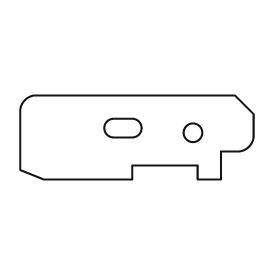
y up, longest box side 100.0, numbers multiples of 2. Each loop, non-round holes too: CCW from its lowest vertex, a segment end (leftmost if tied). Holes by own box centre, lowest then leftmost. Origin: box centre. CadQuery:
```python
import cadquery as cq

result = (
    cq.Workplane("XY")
    .moveTo(-40.0, -18.0)
    .lineTo(-2.0, -18.0)
    .lineTo(-2.0, -12.0)
    .lineTo(26.0, -12.0)
    .lineTo(26.0, -18.0)
    .lineTo(36.0, -18.0)
    .lineTo(36.0, -6.0)
    .lineTo(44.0, -6.0)
    .threePointArc((48.0, -4.0), (50.0, 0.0))
    .lineTo(50.0, 10.0)
    .lineTo(42.0, 18.0)
    .lineTo(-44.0, 18.0)
    .threePointArc((-48.0, 16.0), (-50.0, 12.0))
    .lineTo(-50.0, -14.0)
    .close()
    .moveTo(24.0, 2.0)
    .circle(4.0)
    .moveTo(-10.0, 0.0)
    .lineTo(-2.0, 0.0)
    .threePointArc((2.0, 4.0), (-2.0, 8.0))
    .lineTo(-10.0, 8.0)
    .threePointArc((-14.0, 4.0), (-10.0, 0.0))
    .close()
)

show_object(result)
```